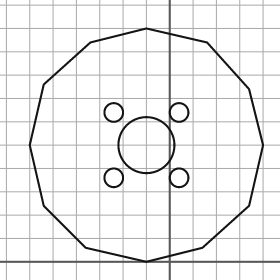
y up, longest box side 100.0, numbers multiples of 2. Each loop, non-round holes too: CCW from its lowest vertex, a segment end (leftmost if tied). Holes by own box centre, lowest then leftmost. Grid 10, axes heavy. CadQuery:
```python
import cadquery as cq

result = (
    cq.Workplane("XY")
    .moveTo(-10.0, 0.0)
    .lineTo(14.0, 6.0)
    .lineTo(34.0, 24.0)
    .lineTo(40.0, 50.0)
    .lineTo(34.0, 74.0)
    .lineTo(16.0, 94.0)
    .lineTo(-10.0, 100.0)
    .lineTo(-34.0, 94.0)
    .lineTo(-54.0, 76.0)
    .lineTo(-60.0, 50.0)
    .lineTo(-54.0, 24.0)
    .lineTo(-36.0, 6.0)
    .close()
    .moveTo(-24.0, 36.0)
    .circle(4.0)
    .moveTo(4.0, 36.0)
    .circle(4.0)
    .moveTo(-10.0, 50.0)
    .circle(12.0)
    .moveTo(-24.0, 64.0)
    .circle(4.0)
    .moveTo(4.0, 64.0)
    .circle(4.0)
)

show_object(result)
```